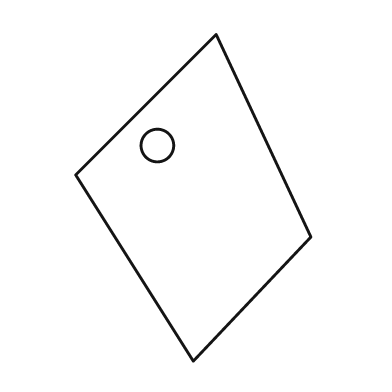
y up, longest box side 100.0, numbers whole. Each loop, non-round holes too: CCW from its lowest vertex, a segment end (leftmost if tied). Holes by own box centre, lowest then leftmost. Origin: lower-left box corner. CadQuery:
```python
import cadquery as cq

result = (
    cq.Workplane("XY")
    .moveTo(36.0, 0.0)
    .lineTo(72.0, 38.0)
    .lineTo(43.0, 100.0)
    .lineTo(0.0, 57.0)
    .close()
    .moveTo(25.0, 66.0)
    .circle(5.0)
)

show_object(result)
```